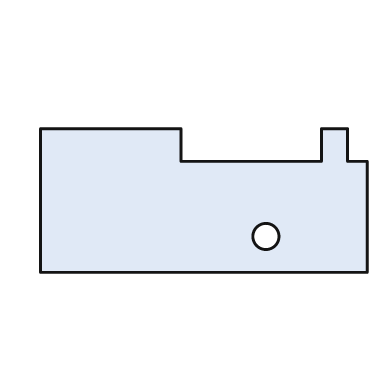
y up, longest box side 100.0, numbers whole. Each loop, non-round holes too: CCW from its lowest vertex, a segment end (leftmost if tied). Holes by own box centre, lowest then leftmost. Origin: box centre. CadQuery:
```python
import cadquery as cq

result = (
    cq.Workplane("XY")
    .moveTo(-50.0, -22.0)
    .lineTo(50.0, -22.0)
    .lineTo(50.0, 12.0)
    .lineTo(44.0, 12.0)
    .lineTo(44.0, 22.0)
    .lineTo(36.0, 22.0)
    .lineTo(36.0, 12.0)
    .lineTo(-7.0, 12.0)
    .lineTo(-7.0, 22.0)
    .lineTo(-50.0, 22.0)
    .close()
    .moveTo(19.0, -11.0)
    .circle(4.0)
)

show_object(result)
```